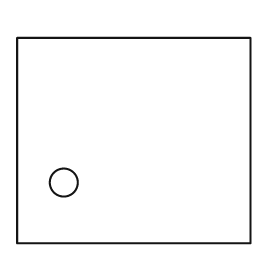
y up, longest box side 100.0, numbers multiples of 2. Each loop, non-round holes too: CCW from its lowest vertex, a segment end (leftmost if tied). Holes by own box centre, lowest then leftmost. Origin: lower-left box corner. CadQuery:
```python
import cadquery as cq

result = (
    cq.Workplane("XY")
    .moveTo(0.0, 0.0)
    .lineTo(100.0, 0.0)
    .lineTo(100.0, 88.0)
    .lineTo(0.0, 88.0)
    .close()
    .moveTo(20.0, 26.0)
    .circle(6.0)
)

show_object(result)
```